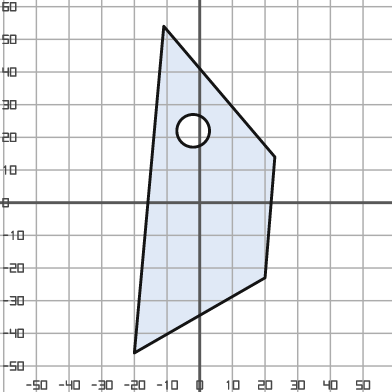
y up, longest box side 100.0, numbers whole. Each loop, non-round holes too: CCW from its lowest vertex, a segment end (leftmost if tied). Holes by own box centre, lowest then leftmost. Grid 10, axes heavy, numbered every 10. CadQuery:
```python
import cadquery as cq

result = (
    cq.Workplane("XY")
    .moveTo(-20.0, -46.0)
    .lineTo(20.0, -23.0)
    .lineTo(23.0, 14.0)
    .lineTo(-11.0, 54.0)
    .close()
    .moveTo(-2.0, 22.0)
    .circle(5.0)
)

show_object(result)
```